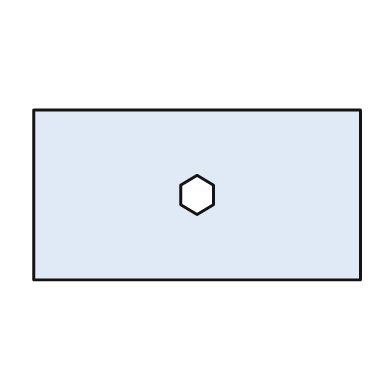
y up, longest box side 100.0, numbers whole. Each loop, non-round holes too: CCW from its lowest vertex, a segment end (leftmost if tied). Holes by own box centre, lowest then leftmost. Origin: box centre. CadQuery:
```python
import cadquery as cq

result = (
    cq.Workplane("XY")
    .moveTo(-50.0, -26.0)
    .lineTo(50.0, -26.0)
    .lineTo(50.0, 26.0)
    .lineTo(-50.0, 26.0)
    .close()
    .moveTo(0.0, -6.0)
    .lineTo(5.0, -3.0)
    .lineTo(5.0, 3.0)
    .lineTo(0.0, 6.0)
    .lineTo(-5.0, 3.0)
    .lineTo(-5.0, -3.0)
    .close()
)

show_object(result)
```